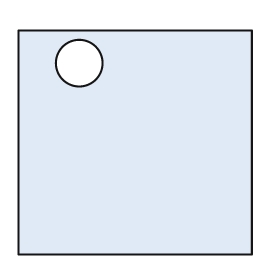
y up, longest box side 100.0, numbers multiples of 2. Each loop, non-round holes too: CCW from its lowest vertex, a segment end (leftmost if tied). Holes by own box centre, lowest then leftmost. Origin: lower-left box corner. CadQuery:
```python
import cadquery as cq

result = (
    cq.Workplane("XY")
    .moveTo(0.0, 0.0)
    .lineTo(100.0, 0.0)
    .lineTo(100.0, 96.0)
    .lineTo(0.0, 96.0)
    .close()
    .moveTo(26.0, 82.0)
    .circle(10.0)
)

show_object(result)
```